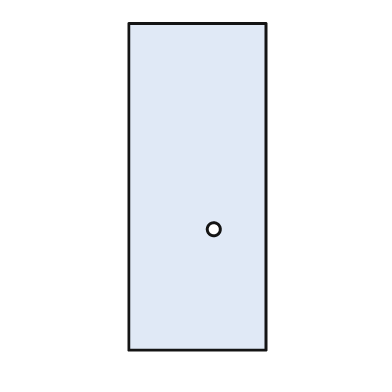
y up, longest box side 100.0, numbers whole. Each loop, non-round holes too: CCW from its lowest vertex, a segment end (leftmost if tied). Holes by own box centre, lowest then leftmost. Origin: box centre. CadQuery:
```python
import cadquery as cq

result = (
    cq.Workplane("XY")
    .moveTo(-21.0, -50.0)
    .lineTo(21.0, -50.0)
    .lineTo(21.0, 50.0)
    .lineTo(-21.0, 50.0)
    .close()
    .moveTo(5.0, -13.0)
    .circle(2.0)
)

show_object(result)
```